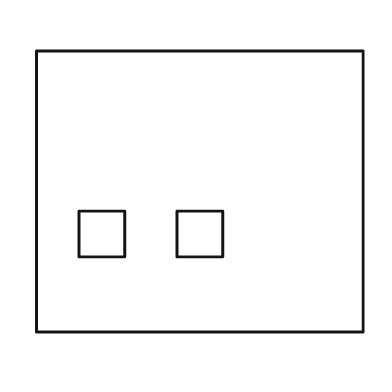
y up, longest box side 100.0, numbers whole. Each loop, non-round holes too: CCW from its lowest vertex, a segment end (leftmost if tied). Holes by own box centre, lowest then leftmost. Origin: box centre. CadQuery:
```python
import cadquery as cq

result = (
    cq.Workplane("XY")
    .moveTo(-50.0, -43.0)
    .lineTo(50.0, -43.0)
    .lineTo(50.0, 43.0)
    .lineTo(-50.0, 43.0)
    .close()
    .moveTo(-37.0, -20.0)
    .lineTo(-23.0, -20.0)
    .lineTo(-23.0, -6.0)
    .lineTo(-37.0, -6.0)
    .close()
    .moveTo(-7.0, -20.0)
    .lineTo(7.0, -20.0)
    .lineTo(7.0, -6.0)
    .lineTo(-7.0, -6.0)
    .close()
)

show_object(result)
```